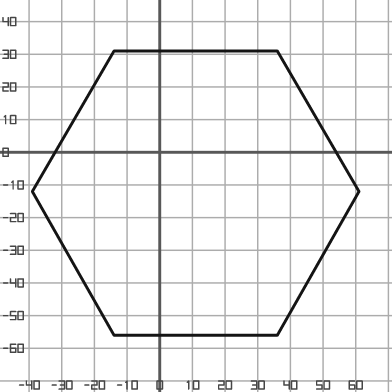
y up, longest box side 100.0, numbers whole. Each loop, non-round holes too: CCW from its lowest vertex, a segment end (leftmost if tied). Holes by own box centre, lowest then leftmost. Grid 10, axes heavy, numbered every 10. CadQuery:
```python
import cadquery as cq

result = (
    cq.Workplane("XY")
    .moveTo(-14.0, -56.0)
    .lineTo(36.0, -56.0)
    .lineTo(61.0, -12.0)
    .lineTo(36.0, 31.0)
    .lineTo(-14.0, 31.0)
    .lineTo(-39.0, -12.0)
    .close()
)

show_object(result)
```